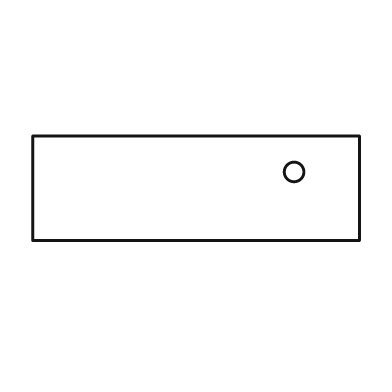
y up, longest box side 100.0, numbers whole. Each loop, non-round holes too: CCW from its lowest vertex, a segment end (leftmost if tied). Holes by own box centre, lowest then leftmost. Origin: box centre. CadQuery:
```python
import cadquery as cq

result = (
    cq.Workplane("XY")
    .moveTo(-50.0, -16.0)
    .lineTo(50.0, -16.0)
    .lineTo(50.0, 16.0)
    .lineTo(-50.0, 16.0)
    .close()
    .moveTo(30.0, 5.0)
    .circle(3.0)
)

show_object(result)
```